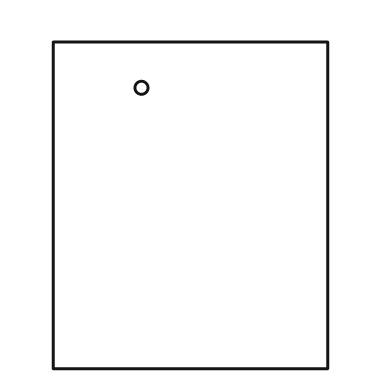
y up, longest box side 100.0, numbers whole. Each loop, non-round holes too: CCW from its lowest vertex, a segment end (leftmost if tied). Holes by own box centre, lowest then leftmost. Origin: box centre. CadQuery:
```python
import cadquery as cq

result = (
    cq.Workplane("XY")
    .moveTo(-42.0, -50.0)
    .lineTo(42.0, -50.0)
    .lineTo(42.0, 50.0)
    .lineTo(-42.0, 50.0)
    .close()
    .moveTo(-15.0, 36.0)
    .circle(2.0)
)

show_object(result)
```